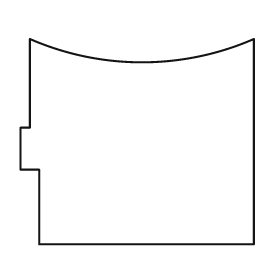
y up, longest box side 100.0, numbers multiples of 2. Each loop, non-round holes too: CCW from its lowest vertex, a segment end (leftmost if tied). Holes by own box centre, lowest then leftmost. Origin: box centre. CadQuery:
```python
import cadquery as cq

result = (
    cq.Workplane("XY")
    .moveTo(-42.0, -44.0)
    .lineTo(50.0, -44.0)
    .lineTo(50.0, 44.0)
    .threePointArc((2.0, 34.0), (-46.0, 44.0))
    .lineTo(-46.0, 6.0)
    .lineTo(-50.0, 6.0)
    .lineTo(-50.0, -12.0)
    .lineTo(-42.0, -12.0)
    .close()
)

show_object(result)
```